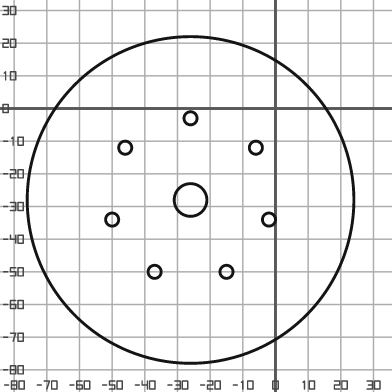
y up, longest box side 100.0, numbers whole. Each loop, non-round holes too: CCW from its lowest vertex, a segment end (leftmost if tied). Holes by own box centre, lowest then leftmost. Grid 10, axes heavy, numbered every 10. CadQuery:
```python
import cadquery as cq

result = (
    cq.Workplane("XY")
    .moveTo(-26.0, -28.0)
    .circle(50.0)
    .moveTo(-37.0, -50.0)
    .circle(2.0)
    .moveTo(-15.0, -50.0)
    .circle(2.0)
    .moveTo(-50.0, -34.0)
    .circle(2.0)
    .moveTo(-2.0, -34.0)
    .circle(2.0)
    .moveTo(-26.0, -28.0)
    .circle(5.0)
    .moveTo(-46.0, -12.0)
    .circle(2.0)
    .moveTo(-6.0, -12.0)
    .circle(2.0)
    .moveTo(-26.0, -3.0)
    .circle(2.0)
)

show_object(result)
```